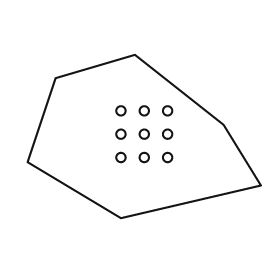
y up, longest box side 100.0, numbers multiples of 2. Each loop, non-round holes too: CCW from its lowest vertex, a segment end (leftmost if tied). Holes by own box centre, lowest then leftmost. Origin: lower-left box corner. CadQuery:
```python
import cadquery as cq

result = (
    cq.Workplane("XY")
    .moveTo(40.0, 0.0)
    .lineTo(100.0, 14.0)
    .lineTo(84.0, 40.0)
    .lineTo(46.0, 70.0)
    .lineTo(12.0, 60.0)
    .lineTo(0.0, 24.0)
    .close()
    .moveTo(40.0, 26.0)
    .circle(2.0)
    .moveTo(50.0, 26.0)
    .circle(2.0)
    .moveTo(60.0, 26.0)
    .circle(2.0)
    .moveTo(40.0, 36.0)
    .circle(2.0)
    .moveTo(50.0, 36.0)
    .circle(2.0)
    .moveTo(60.0, 36.0)
    .circle(2.0)
    .moveTo(40.0, 46.0)
    .circle(2.0)
    .moveTo(50.0, 46.0)
    .circle(2.0)
    .moveTo(60.0, 46.0)
    .circle(2.0)
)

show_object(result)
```